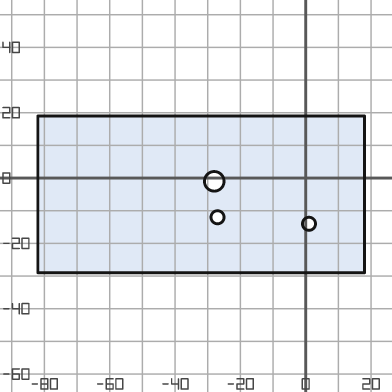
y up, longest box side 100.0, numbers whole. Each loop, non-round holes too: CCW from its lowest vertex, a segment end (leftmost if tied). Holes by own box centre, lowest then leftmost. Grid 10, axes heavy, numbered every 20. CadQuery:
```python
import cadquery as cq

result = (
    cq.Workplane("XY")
    .moveTo(-82.0, -29.0)
    .lineTo(18.0, -29.0)
    .lineTo(18.0, 19.0)
    .lineTo(-82.0, 19.0)
    .close()
    .moveTo(1.0, -14.0)
    .circle(2.0)
    .moveTo(-27.0, -12.0)
    .circle(2.0)
    .moveTo(-28.0, -1.0)
    .circle(3.0)
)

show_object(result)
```